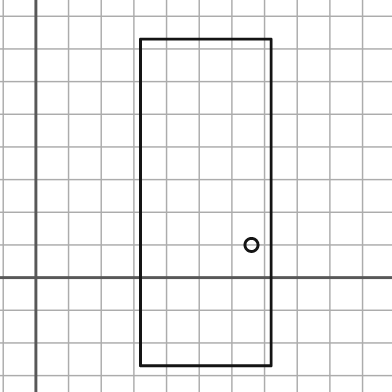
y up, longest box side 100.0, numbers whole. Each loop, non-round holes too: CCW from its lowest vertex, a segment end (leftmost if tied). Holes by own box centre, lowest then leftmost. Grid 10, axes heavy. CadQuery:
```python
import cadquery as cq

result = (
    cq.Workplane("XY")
    .moveTo(32.0, -27.0)
    .lineTo(72.0, -27.0)
    .lineTo(72.0, 73.0)
    .lineTo(32.0, 73.0)
    .close()
    .moveTo(66.0, 10.0)
    .circle(2.0)
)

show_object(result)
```